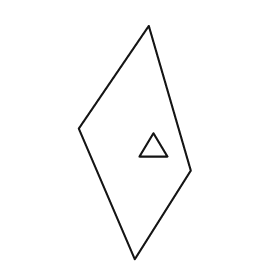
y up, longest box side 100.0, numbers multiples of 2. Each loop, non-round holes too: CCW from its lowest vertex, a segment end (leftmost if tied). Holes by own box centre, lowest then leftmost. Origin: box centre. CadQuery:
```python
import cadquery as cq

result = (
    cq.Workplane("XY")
    .moveTo(0.0, -50.0)
    .lineTo(24.0, -12.0)
    .lineTo(6.0, 50.0)
    .lineTo(-24.0, 6.0)
    .close()
    .moveTo(2.0, -6.0)
    .lineTo(14.0, -6.0)
    .lineTo(8.0, 4.0)
    .close()
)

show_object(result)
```